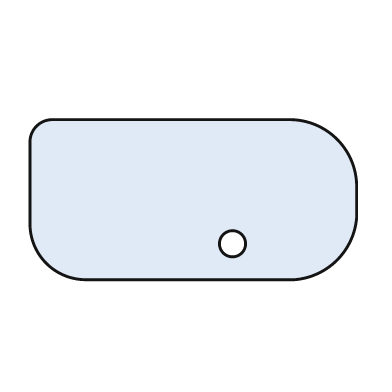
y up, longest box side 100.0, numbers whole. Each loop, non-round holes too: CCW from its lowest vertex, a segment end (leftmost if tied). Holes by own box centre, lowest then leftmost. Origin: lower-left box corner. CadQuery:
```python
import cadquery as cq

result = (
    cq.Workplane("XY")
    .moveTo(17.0, 0.0)
    .lineTo(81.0, 0.0)
    .threePointArc((94.0, 6.0), (100.0, 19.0))
    .lineTo(100.0, 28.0)
    .threePointArc((94.0, 43.0), (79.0, 49.0))
    .lineTo(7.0, 49.0)
    .threePointArc((2.0, 47.0), (0.0, 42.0))
    .lineTo(0.0, 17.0)
    .threePointArc((5.0, 5.0), (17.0, 0.0))
    .close()
    .moveTo(62.0, 11.0)
    .circle(4.0)
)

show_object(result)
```